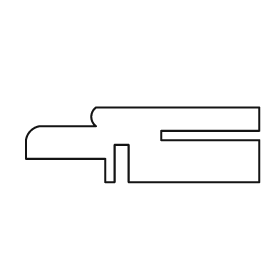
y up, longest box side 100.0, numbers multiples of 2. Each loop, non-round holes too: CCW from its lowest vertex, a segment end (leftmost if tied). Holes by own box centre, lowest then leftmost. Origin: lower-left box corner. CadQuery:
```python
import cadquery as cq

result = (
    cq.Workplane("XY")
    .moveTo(34.0, 0.0)
    .lineTo(38.0, 0.0)
    .lineTo(38.0, 16.0)
    .lineTo(44.0, 16.0)
    .lineTo(44.0, 0.0)
    .lineTo(100.0, 0.0)
    .lineTo(100.0, 18.0)
    .lineTo(58.0, 18.0)
    .lineTo(58.0, 22.0)
    .lineTo(100.0, 22.0)
    .lineTo(100.0, 32.0)
    .lineTo(30.0, 32.0)
    .threePointArc((28.0, 28.0), (30.0, 24.0))
    .lineTo(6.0, 24.0)
    .threePointArc((2.0, 22.0), (0.0, 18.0))
    .lineTo(0.0, 10.0)
    .lineTo(34.0, 10.0)
    .close()
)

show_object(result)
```